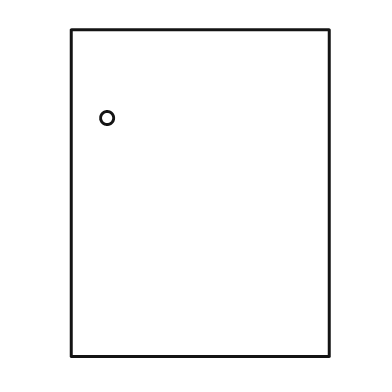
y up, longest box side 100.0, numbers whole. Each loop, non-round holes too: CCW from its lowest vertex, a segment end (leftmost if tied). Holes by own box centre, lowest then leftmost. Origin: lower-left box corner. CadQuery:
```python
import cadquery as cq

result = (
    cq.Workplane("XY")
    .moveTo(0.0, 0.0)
    .lineTo(79.0, 0.0)
    .lineTo(79.0, 100.0)
    .lineTo(0.0, 100.0)
    .close()
    .moveTo(11.0, 73.0)
    .circle(2.0)
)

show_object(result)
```